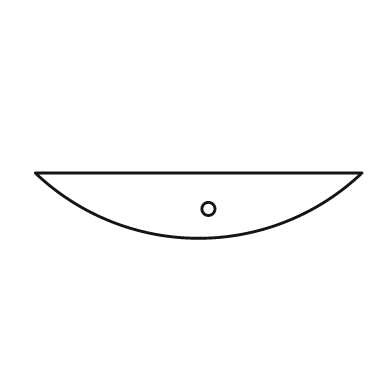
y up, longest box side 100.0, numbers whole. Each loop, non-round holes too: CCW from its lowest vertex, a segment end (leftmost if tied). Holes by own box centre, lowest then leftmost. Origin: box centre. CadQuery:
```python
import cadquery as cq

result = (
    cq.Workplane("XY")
    .moveTo(-50.0, 10.0)
    .threePointArc((0.0, -10.0), (50.0, 10.0))
    .close()
    .moveTo(3.0, -1.0)
    .circle(2.0)
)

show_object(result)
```